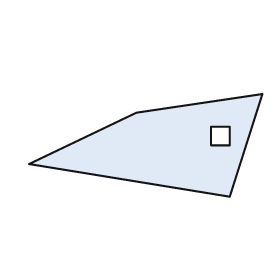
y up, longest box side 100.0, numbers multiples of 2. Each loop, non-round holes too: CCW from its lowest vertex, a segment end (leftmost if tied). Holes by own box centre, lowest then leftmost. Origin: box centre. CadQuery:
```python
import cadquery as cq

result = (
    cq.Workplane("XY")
    .moveTo(36.0, -22.0)
    .lineTo(50.0, 22.0)
    .lineTo(-4.0, 14.0)
    .lineTo(-50.0, -8.0)
    .close()
    .moveTo(28.0, 0.0)
    .lineTo(36.0, 0.0)
    .lineTo(36.0, 8.0)
    .lineTo(28.0, 8.0)
    .close()
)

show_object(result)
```